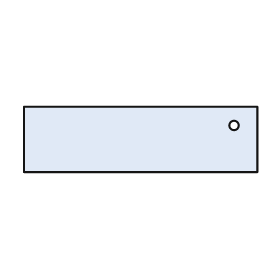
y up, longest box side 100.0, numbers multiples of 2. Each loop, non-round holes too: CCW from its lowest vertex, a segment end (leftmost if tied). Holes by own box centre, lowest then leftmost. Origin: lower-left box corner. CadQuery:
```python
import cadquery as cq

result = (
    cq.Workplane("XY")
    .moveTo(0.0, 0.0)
    .lineTo(100.0, 0.0)
    .lineTo(100.0, 28.0)
    .lineTo(0.0, 28.0)
    .close()
    .moveTo(90.0, 20.0)
    .circle(2.0)
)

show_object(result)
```